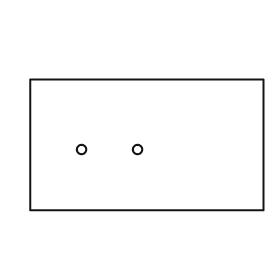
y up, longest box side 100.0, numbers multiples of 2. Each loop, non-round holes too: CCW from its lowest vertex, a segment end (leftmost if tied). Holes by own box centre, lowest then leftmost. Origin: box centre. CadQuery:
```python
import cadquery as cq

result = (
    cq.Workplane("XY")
    .moveTo(-50.0, -28.0)
    .lineTo(50.0, -28.0)
    .lineTo(50.0, 28.0)
    .lineTo(-50.0, 28.0)
    .close()
    .moveTo(-28.0, -2.0)
    .circle(2.0)
    .moveTo(-4.0, -2.0)
    .circle(2.0)
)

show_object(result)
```